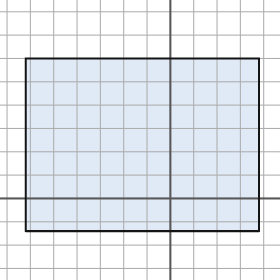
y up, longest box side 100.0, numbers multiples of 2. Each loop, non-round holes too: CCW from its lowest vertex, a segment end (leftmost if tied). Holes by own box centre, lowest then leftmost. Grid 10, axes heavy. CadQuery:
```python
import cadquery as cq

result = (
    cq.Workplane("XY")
    .moveTo(-62.0, -14.0)
    .lineTo(38.0, -14.0)
    .lineTo(38.0, 60.0)
    .lineTo(-62.0, 60.0)
    .close()
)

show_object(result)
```